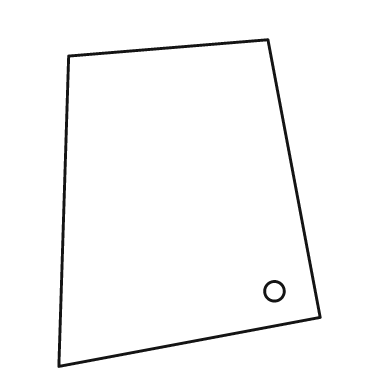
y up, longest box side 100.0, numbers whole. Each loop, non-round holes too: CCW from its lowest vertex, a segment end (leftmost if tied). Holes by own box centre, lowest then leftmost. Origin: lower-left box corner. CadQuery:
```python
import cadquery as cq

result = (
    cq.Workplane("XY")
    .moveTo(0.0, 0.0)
    .lineTo(80.0, 15.0)
    .lineTo(64.0, 100.0)
    .lineTo(3.0, 95.0)
    .close()
    .moveTo(66.0, 23.0)
    .circle(3.0)
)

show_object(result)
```